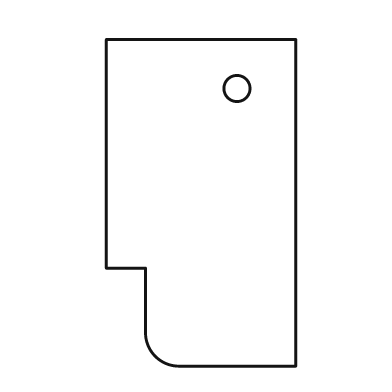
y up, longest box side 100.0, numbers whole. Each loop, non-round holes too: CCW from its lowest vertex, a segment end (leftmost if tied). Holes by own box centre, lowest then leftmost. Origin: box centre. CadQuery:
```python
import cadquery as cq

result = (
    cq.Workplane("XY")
    .moveTo(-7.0, -50.0)
    .lineTo(29.0, -50.0)
    .lineTo(29.0, 50.0)
    .lineTo(-29.0, 50.0)
    .lineTo(-29.0, -20.0)
    .lineTo(-17.0, -20.0)
    .lineTo(-17.0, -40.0)
    .threePointArc((-14.0, -47.0), (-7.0, -50.0))
    .close()
    .moveTo(11.0, 35.0)
    .circle(4.0)
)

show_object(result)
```